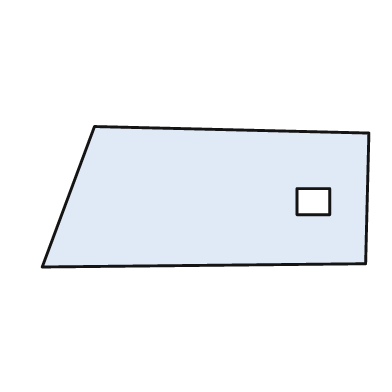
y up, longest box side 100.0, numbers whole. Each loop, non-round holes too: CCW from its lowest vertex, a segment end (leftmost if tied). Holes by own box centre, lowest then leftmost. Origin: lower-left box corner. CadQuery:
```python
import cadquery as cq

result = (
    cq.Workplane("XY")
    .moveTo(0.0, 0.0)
    .lineTo(99.0, 1.0)
    .lineTo(100.0, 41.0)
    .lineTo(16.0, 43.0)
    .close()
    .moveTo(78.0, 16.0)
    .lineTo(88.0, 16.0)
    .lineTo(88.0, 24.0)
    .lineTo(78.0, 24.0)
    .close()
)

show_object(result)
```